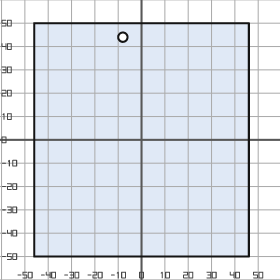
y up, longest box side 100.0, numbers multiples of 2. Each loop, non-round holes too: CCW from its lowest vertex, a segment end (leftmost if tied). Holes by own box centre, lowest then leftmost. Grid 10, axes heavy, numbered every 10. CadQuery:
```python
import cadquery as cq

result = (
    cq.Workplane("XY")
    .moveTo(-46.0, -50.0)
    .lineTo(46.0, -50.0)
    .lineTo(46.0, 50.0)
    .lineTo(-46.0, 50.0)
    .close()
    .moveTo(-8.0, 44.0)
    .circle(2.0)
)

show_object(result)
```